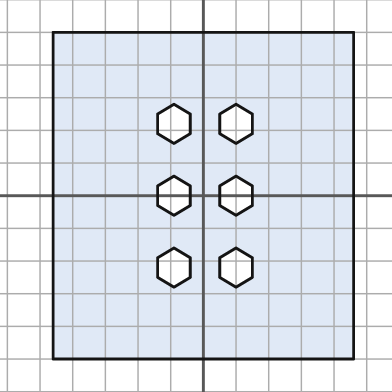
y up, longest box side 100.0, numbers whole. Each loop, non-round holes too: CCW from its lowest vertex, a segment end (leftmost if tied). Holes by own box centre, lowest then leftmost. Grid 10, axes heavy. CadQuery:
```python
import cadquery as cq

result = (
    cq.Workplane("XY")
    .moveTo(-46.0, -50.0)
    .lineTo(46.0, -50.0)
    .lineTo(46.0, 50.0)
    .lineTo(-46.0, 50.0)
    .close()
    .moveTo(-9.0, -28.0)
    .lineTo(-4.0, -25.0)
    .lineTo(-4.0, -19.0)
    .lineTo(-9.0, -16.0)
    .lineTo(-14.0, -19.0)
    .lineTo(-14.0, -25.0)
    .close()
    .moveTo(10.0, -28.0)
    .lineTo(15.0, -25.0)
    .lineTo(15.0, -19.0)
    .lineTo(10.0, -16.0)
    .lineTo(5.0, -19.0)
    .lineTo(5.0, -25.0)
    .close()
    .moveTo(-9.0, -6.0)
    .lineTo(-4.0, -3.0)
    .lineTo(-4.0, 3.0)
    .lineTo(-9.0, 6.0)
    .lineTo(-14.0, 3.0)
    .lineTo(-14.0, -3.0)
    .close()
    .moveTo(10.0, -6.0)
    .lineTo(15.0, -3.0)
    .lineTo(15.0, 3.0)
    .lineTo(10.0, 6.0)
    .lineTo(5.0, 3.0)
    .lineTo(5.0, -3.0)
    .close()
    .moveTo(-9.0, 16.0)
    .lineTo(-4.0, 19.0)
    .lineTo(-4.0, 25.0)
    .lineTo(-9.0, 28.0)
    .lineTo(-14.0, 25.0)
    .lineTo(-14.0, 19.0)
    .close()
    .moveTo(10.0, 16.0)
    .lineTo(15.0, 19.0)
    .lineTo(15.0, 25.0)
    .lineTo(10.0, 28.0)
    .lineTo(5.0, 25.0)
    .lineTo(5.0, 19.0)
    .close()
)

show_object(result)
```